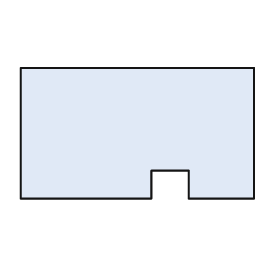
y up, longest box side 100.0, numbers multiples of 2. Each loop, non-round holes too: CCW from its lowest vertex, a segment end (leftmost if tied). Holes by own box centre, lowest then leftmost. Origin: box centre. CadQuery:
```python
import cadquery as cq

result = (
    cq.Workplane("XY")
    .moveTo(-50.0, -28.0)
    .lineTo(6.0, -28.0)
    .lineTo(6.0, -16.0)
    .lineTo(22.0, -16.0)
    .lineTo(22.0, -28.0)
    .lineTo(50.0, -28.0)
    .lineTo(50.0, 28.0)
    .lineTo(-50.0, 28.0)
    .close()
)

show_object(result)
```